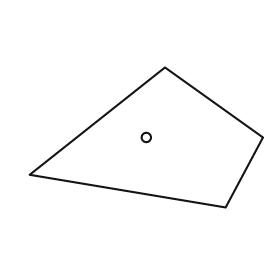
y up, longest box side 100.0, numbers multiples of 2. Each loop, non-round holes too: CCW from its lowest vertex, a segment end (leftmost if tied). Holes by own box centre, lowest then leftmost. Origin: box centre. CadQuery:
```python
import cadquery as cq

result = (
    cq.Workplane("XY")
    .moveTo(34.0, -30.0)
    .lineTo(50.0, 0.0)
    .lineTo(8.0, 30.0)
    .lineTo(-50.0, -16.0)
    .close()
    .moveTo(0.0, 0.0)
    .circle(2.0)
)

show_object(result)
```